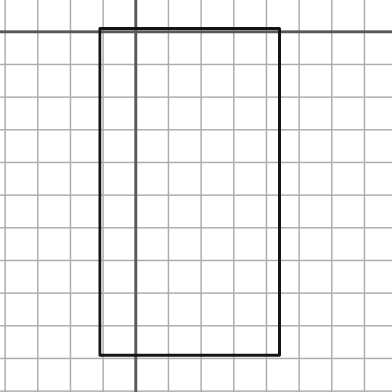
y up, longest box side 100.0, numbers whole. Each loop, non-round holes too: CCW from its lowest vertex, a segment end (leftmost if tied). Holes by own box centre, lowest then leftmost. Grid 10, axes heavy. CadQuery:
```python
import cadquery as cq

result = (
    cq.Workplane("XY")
    .moveTo(-11.0, -99.0)
    .lineTo(44.0, -99.0)
    .lineTo(44.0, 1.0)
    .lineTo(-11.0, 1.0)
    .close()
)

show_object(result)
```